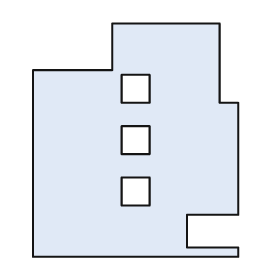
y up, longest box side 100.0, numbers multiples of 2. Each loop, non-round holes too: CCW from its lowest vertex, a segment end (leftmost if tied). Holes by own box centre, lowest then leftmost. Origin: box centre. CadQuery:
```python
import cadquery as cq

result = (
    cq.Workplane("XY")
    .moveTo(-44.0, -50.0)
    .lineTo(44.0, -50.0)
    .lineTo(44.0, -46.0)
    .lineTo(22.0, -46.0)
    .lineTo(22.0, -32.0)
    .lineTo(44.0, -32.0)
    .lineTo(44.0, 16.0)
    .lineTo(36.0, 16.0)
    .lineTo(36.0, 50.0)
    .lineTo(-10.0, 50.0)
    .lineTo(-10.0, 30.0)
    .lineTo(-44.0, 30.0)
    .close()
    .moveTo(-6.0, -28.0)
    .lineTo(6.0, -28.0)
    .lineTo(6.0, -16.0)
    .lineTo(-6.0, -16.0)
    .close()
    .moveTo(-6.0, -6.0)
    .lineTo(6.0, -6.0)
    .lineTo(6.0, 6.0)
    .lineTo(-6.0, 6.0)
    .close()
    .moveTo(-6.0, 16.0)
    .lineTo(6.0, 16.0)
    .lineTo(6.0, 28.0)
    .lineTo(-6.0, 28.0)
    .close()
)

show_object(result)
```